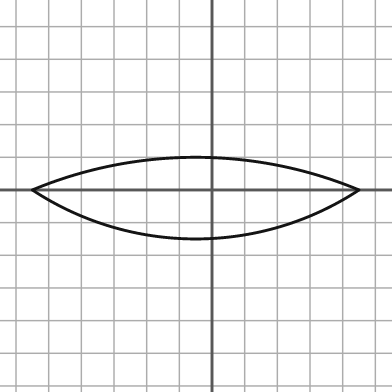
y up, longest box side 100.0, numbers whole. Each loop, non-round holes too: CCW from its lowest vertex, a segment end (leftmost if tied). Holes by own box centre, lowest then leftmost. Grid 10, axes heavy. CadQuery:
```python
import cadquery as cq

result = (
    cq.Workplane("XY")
    .moveTo(-55.0, 0.0)
    .threePointArc((-5.0, -15.0), (45.0, 0.0))
    .threePointArc((-5.0, 10.0), (-55.0, 0.0))
    .close()
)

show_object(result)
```